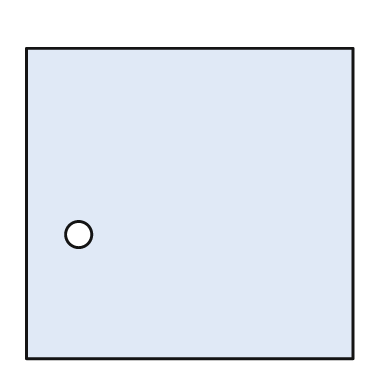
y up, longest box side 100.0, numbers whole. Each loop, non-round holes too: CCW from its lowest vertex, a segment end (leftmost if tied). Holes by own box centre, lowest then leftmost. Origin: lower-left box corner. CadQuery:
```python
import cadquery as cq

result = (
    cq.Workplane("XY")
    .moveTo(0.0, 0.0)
    .lineTo(100.0, 0.0)
    .lineTo(100.0, 95.0)
    .lineTo(0.0, 95.0)
    .close()
    .moveTo(16.0, 38.0)
    .circle(4.0)
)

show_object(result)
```